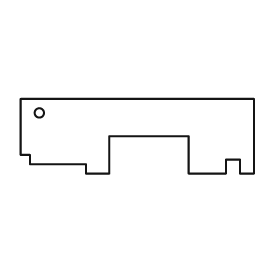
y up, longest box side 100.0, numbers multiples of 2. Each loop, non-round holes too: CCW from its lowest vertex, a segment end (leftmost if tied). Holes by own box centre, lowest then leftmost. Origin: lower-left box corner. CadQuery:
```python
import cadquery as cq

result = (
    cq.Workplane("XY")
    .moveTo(28.0, 0.0)
    .lineTo(38.0, 0.0)
    .lineTo(38.0, 16.0)
    .lineTo(72.0, 16.0)
    .lineTo(72.0, 0.0)
    .lineTo(88.0, 0.0)
    .lineTo(88.0, 6.0)
    .lineTo(94.0, 6.0)
    .lineTo(94.0, 0.0)
    .lineTo(100.0, 0.0)
    .lineTo(100.0, 32.0)
    .lineTo(0.0, 32.0)
    .lineTo(0.0, 8.0)
    .lineTo(4.0, 8.0)
    .lineTo(4.0, 4.0)
    .lineTo(28.0, 4.0)
    .close()
    .moveTo(8.0, 26.0)
    .circle(2.0)
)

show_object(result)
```